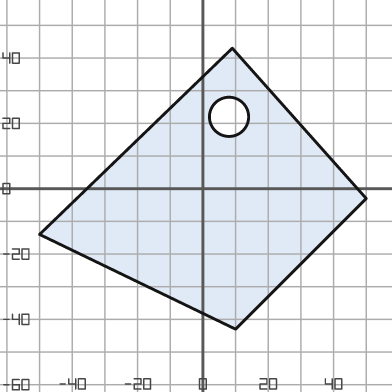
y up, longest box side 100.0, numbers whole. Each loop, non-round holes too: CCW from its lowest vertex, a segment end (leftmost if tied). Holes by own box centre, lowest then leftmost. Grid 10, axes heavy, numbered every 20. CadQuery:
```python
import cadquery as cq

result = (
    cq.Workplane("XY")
    .moveTo(10.0, -43.0)
    .lineTo(50.0, -3.0)
    .lineTo(9.0, 43.0)
    .lineTo(-50.0, -14.0)
    .close()
    .moveTo(8.0, 22.0)
    .circle(6.0)
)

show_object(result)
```